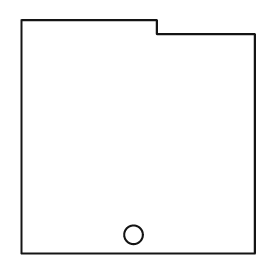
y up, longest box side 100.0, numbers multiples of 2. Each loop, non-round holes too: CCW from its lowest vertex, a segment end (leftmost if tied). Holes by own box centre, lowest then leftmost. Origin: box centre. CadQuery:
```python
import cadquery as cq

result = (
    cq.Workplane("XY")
    .moveTo(-50.0, -50.0)
    .lineTo(50.0, -50.0)
    .lineTo(50.0, 44.0)
    .lineTo(8.0, 44.0)
    .lineTo(8.0, 50.0)
    .lineTo(-50.0, 50.0)
    .close()
    .moveTo(-2.0, -42.0)
    .circle(4.0)
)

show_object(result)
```